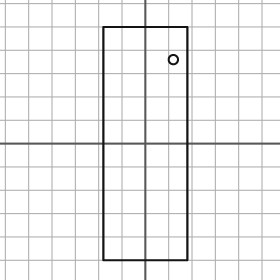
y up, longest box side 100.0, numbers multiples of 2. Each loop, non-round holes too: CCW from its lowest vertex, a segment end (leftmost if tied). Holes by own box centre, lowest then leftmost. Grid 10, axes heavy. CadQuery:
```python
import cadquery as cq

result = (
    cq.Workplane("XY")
    .moveTo(-18.0, -50.0)
    .lineTo(18.0, -50.0)
    .lineTo(18.0, 50.0)
    .lineTo(-18.0, 50.0)
    .close()
    .moveTo(12.0, 36.0)
    .circle(2.0)
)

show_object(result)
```